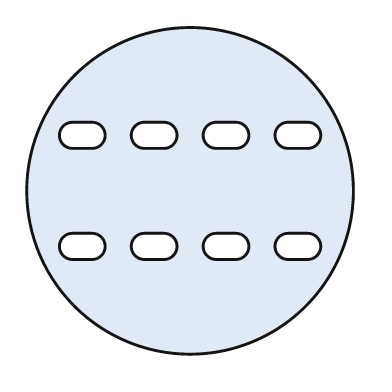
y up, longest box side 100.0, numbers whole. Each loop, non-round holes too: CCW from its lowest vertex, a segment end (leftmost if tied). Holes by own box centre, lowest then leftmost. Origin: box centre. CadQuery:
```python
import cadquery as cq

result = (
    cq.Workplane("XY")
    .moveTo(0.0, 0.0)
    .circle(50.0)
    .moveTo(-36.0, -21.0)
    .lineTo(-30.0, -21.0)
    .threePointArc((-26.0, -17.0), (-30.0, -13.0))
    .lineTo(-36.0, -13.0)
    .threePointArc((-40.0, -17.0), (-36.0, -21.0))
    .close()
    .moveTo(-14.0, -21.0)
    .lineTo(-8.0, -21.0)
    .threePointArc((-4.0, -17.0), (-8.0, -13.0))
    .lineTo(-14.0, -13.0)
    .threePointArc((-18.0, -17.0), (-14.0, -21.0))
    .close()
    .moveTo(8.0, -21.0)
    .lineTo(14.0, -21.0)
    .threePointArc((18.0, -17.0), (14.0, -13.0))
    .lineTo(8.0, -13.0)
    .threePointArc((4.0, -17.0), (8.0, -21.0))
    .close()
    .moveTo(30.0, -21.0)
    .lineTo(36.0, -21.0)
    .threePointArc((40.0, -17.0), (36.0, -13.0))
    .lineTo(30.0, -13.0)
    .threePointArc((26.0, -17.0), (30.0, -21.0))
    .close()
    .moveTo(-36.0, 13.0)
    .lineTo(-30.0, 13.0)
    .threePointArc((-26.0, 17.0), (-30.0, 21.0))
    .lineTo(-36.0, 21.0)
    .threePointArc((-40.0, 17.0), (-36.0, 13.0))
    .close()
    .moveTo(-14.0, 13.0)
    .lineTo(-8.0, 13.0)
    .threePointArc((-4.0, 17.0), (-8.0, 21.0))
    .lineTo(-14.0, 21.0)
    .threePointArc((-18.0, 17.0), (-14.0, 13.0))
    .close()
    .moveTo(8.0, 13.0)
    .lineTo(14.0, 13.0)
    .threePointArc((18.0, 17.0), (14.0, 21.0))
    .lineTo(8.0, 21.0)
    .threePointArc((4.0, 17.0), (8.0, 13.0))
    .close()
    .moveTo(30.0, 13.0)
    .lineTo(36.0, 13.0)
    .threePointArc((40.0, 17.0), (36.0, 21.0))
    .lineTo(30.0, 21.0)
    .threePointArc((26.0, 17.0), (30.0, 13.0))
    .close()
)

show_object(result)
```